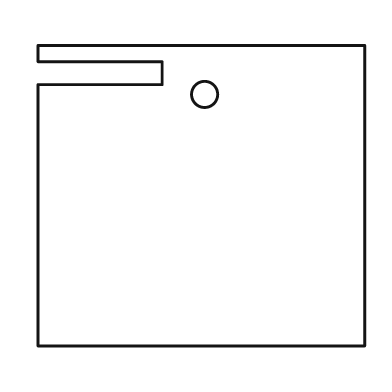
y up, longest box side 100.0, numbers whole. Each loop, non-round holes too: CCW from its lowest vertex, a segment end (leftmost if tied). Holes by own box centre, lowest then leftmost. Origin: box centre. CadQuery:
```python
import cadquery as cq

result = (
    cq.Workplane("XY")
    .moveTo(-50.0, -46.0)
    .lineTo(50.0, -46.0)
    .lineTo(50.0, 46.0)
    .lineTo(-50.0, 46.0)
    .lineTo(-50.0, 41.0)
    .lineTo(-12.0, 41.0)
    .lineTo(-12.0, 34.0)
    .lineTo(-50.0, 34.0)
    .close()
    .moveTo(1.0, 31.0)
    .circle(4.0)
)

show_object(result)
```